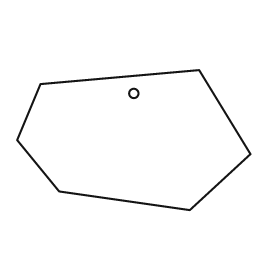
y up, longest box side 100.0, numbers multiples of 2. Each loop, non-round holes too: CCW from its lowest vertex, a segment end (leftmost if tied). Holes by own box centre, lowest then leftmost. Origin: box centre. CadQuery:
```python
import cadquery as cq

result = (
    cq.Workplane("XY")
    .moveTo(24.0, -30.0)
    .lineTo(50.0, -6.0)
    .lineTo(28.0, 30.0)
    .lineTo(-40.0, 24.0)
    .lineTo(-50.0, 0.0)
    .lineTo(-32.0, -22.0)
    .close()
    .moveTo(0.0, 20.0)
    .circle(2.0)
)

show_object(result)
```